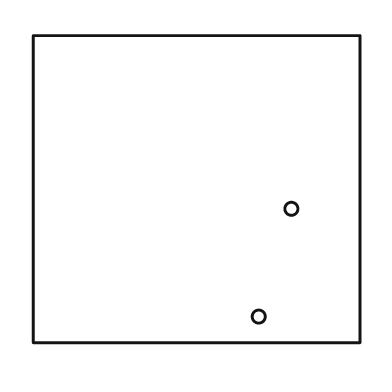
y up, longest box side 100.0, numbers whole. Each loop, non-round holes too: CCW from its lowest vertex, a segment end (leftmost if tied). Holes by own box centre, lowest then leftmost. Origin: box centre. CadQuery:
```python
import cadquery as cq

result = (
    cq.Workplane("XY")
    .moveTo(-50.0, -47.0)
    .lineTo(50.0, -47.0)
    .lineTo(50.0, 47.0)
    .lineTo(-50.0, 47.0)
    .close()
    .moveTo(19.0, -39.0)
    .circle(2.0)
    .moveTo(29.0, -6.0)
    .circle(2.0)
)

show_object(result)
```